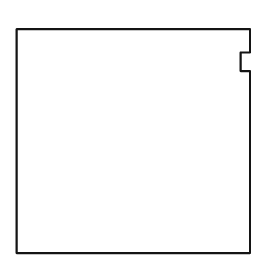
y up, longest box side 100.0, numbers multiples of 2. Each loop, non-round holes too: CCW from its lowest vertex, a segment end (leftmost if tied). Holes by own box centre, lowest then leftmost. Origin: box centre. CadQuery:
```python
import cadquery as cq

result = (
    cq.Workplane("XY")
    .moveTo(-50.0, -48.0)
    .lineTo(50.0, -48.0)
    .lineTo(50.0, 30.0)
    .lineTo(46.0, 30.0)
    .lineTo(46.0, 38.0)
    .lineTo(50.0, 38.0)
    .lineTo(50.0, 48.0)
    .lineTo(-50.0, 48.0)
    .close()
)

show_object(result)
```